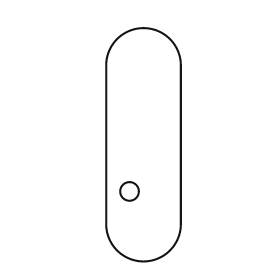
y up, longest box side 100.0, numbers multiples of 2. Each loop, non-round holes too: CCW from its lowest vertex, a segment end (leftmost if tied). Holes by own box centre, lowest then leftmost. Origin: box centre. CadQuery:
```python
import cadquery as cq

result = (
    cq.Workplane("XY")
    .moveTo(-16.0, -34.0)
    .threePointArc((0.0, -50.0), (16.0, -34.0))
    .lineTo(16.0, 34.0)
    .threePointArc((0.0, 50.0), (-16.0, 34.0))
    .close()
    .moveTo(-6.0, -20.0)
    .circle(4.0)
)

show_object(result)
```